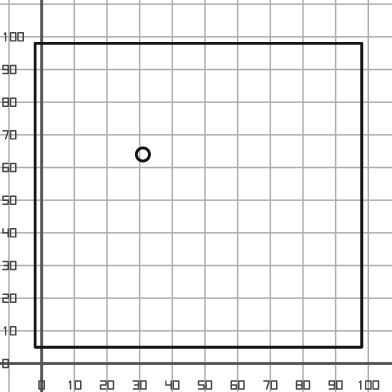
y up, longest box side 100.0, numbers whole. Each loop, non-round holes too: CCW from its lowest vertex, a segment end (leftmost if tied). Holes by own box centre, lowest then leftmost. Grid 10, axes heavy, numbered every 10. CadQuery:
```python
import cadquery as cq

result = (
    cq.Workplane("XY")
    .moveTo(-2.0, 5.0)
    .lineTo(98.0, 5.0)
    .lineTo(98.0, 98.0)
    .lineTo(-2.0, 98.0)
    .close()
    .moveTo(31.0, 64.0)
    .circle(2.0)
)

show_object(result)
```